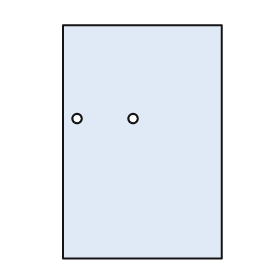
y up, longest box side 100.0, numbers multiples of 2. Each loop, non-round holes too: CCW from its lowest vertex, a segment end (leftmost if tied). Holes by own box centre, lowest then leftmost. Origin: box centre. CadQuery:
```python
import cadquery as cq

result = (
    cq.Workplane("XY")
    .moveTo(-34.0, -50.0)
    .lineTo(34.0, -50.0)
    .lineTo(34.0, 50.0)
    .lineTo(-34.0, 50.0)
    .close()
    .moveTo(-28.0, 10.0)
    .circle(2.0)
    .moveTo(-4.0, 10.0)
    .circle(2.0)
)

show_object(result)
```